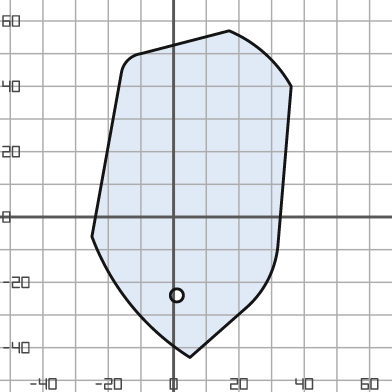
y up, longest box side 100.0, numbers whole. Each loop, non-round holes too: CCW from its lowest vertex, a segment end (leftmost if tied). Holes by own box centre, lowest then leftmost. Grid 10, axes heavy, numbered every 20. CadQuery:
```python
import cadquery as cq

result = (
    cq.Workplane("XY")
    .moveTo(5.0, -43.0)
    .lineTo(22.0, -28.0)
    .threePointArc((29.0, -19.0), (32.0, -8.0))
    .lineTo(36.0, 40.0)
    .threePointArc((28.0, 50.0), (17.0, 57.0))
    .lineTo(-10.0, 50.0)
    .threePointArc((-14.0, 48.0), (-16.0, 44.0))
    .lineTo(-25.0, -6.0)
    .threePointArc((-13.0, -27.0), (5.0, -43.0))
    .close()
    .moveTo(1.0, -24.0)
    .circle(2.0)
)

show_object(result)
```